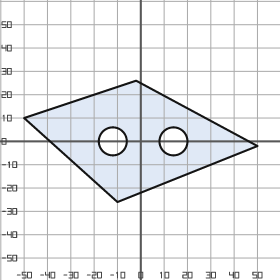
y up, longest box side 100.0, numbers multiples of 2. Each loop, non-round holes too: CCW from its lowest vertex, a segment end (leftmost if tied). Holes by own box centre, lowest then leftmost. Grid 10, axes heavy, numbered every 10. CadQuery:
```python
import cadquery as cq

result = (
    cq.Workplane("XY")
    .moveTo(-10.0, -26.0)
    .lineTo(50.0, -2.0)
    .lineTo(-2.0, 26.0)
    .lineTo(-50.0, 10.0)
    .close()
    .moveTo(-12.0, 0.0)
    .circle(6.0)
    .moveTo(14.0, 0.0)
    .circle(6.0)
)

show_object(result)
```